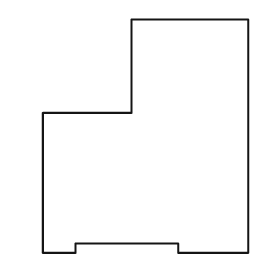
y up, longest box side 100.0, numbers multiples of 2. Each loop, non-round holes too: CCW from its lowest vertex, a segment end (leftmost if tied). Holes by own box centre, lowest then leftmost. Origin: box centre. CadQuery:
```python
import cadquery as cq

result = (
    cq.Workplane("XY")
    .moveTo(-44.0, -50.0)
    .lineTo(-30.0, -50.0)
    .lineTo(-30.0, -46.0)
    .lineTo(14.0, -46.0)
    .lineTo(14.0, -50.0)
    .lineTo(44.0, -50.0)
    .lineTo(44.0, 50.0)
    .lineTo(-6.0, 50.0)
    .lineTo(-6.0, 10.0)
    .lineTo(-44.0, 10.0)
    .close()
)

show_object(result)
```